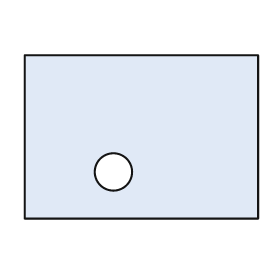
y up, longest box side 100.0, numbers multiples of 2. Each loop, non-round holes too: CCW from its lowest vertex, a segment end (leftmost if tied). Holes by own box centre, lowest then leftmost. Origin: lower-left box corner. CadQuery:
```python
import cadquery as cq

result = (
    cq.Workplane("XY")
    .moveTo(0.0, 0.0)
    .lineTo(100.0, 0.0)
    .lineTo(100.0, 70.0)
    .lineTo(0.0, 70.0)
    .close()
    .moveTo(38.0, 20.0)
    .circle(8.0)
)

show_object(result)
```